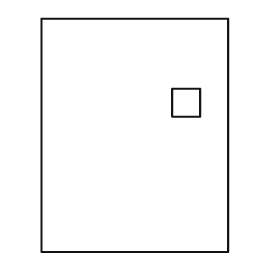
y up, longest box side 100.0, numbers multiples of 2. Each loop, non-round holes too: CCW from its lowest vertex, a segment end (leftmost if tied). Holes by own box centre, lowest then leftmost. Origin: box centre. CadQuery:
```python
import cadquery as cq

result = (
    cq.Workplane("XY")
    .moveTo(-40.0, -50.0)
    .lineTo(40.0, -50.0)
    .lineTo(40.0, 50.0)
    .lineTo(-40.0, 50.0)
    .close()
    .moveTo(16.0, 8.0)
    .lineTo(28.0, 8.0)
    .lineTo(28.0, 20.0)
    .lineTo(16.0, 20.0)
    .close()
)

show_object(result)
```